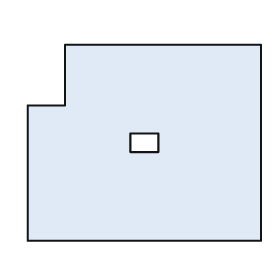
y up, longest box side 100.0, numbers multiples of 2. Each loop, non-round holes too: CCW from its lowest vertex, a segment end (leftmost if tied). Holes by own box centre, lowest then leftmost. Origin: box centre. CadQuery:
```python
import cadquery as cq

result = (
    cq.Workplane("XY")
    .moveTo(-50.0, -42.0)
    .lineTo(50.0, -42.0)
    .lineTo(50.0, 42.0)
    .lineTo(-34.0, 42.0)
    .lineTo(-34.0, 16.0)
    .lineTo(-50.0, 16.0)
    .close()
    .moveTo(-6.0, -4.0)
    .lineTo(6.0, -4.0)
    .lineTo(6.0, 4.0)
    .lineTo(-6.0, 4.0)
    .close()
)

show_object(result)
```